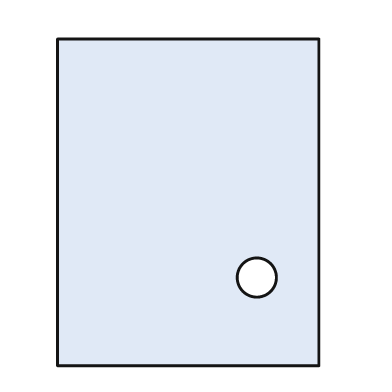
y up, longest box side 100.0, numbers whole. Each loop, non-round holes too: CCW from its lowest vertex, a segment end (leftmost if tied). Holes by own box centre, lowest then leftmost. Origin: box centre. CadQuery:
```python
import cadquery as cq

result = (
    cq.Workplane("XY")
    .moveTo(-40.0, -50.0)
    .lineTo(40.0, -50.0)
    .lineTo(40.0, 50.0)
    .lineTo(-40.0, 50.0)
    .close()
    .moveTo(21.0, -23.0)
    .circle(6.0)
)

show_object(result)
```